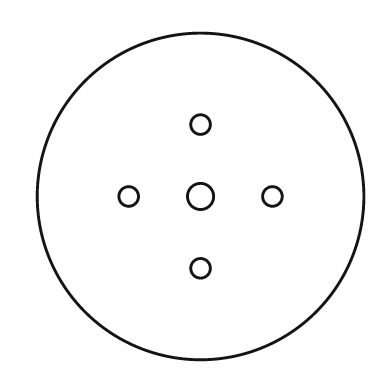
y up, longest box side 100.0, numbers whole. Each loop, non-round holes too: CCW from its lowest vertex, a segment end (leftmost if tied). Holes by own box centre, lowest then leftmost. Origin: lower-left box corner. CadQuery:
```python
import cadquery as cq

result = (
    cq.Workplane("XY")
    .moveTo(50.0, 50.0)
    .circle(50.0)
    .moveTo(50.0, 28.0)
    .circle(3.0)
    .moveTo(28.0, 50.0)
    .circle(3.0)
    .moveTo(50.0, 50.0)
    .circle(4.0)
    .moveTo(72.0, 50.0)
    .circle(3.0)
    .moveTo(50.0, 72.0)
    .circle(3.0)
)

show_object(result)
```